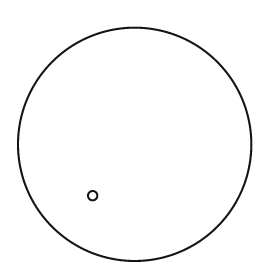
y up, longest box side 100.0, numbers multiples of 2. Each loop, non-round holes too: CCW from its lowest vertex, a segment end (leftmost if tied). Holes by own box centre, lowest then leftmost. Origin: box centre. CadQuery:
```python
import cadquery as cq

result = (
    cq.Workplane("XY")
    .moveTo(0.0, 0.0)
    .circle(50.0)
    .moveTo(-18.0, -22.0)
    .circle(2.0)
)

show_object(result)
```